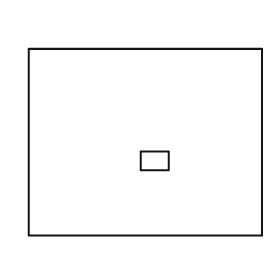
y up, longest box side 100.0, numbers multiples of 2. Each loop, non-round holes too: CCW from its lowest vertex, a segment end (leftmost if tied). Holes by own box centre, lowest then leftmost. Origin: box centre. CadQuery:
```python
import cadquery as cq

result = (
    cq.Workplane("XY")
    .moveTo(-50.0, -40.0)
    .lineTo(50.0, -40.0)
    .lineTo(50.0, 40.0)
    .lineTo(-50.0, 40.0)
    .close()
    .moveTo(-2.0, -12.0)
    .lineTo(10.0, -12.0)
    .lineTo(10.0, -4.0)
    .lineTo(-2.0, -4.0)
    .close()
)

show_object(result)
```